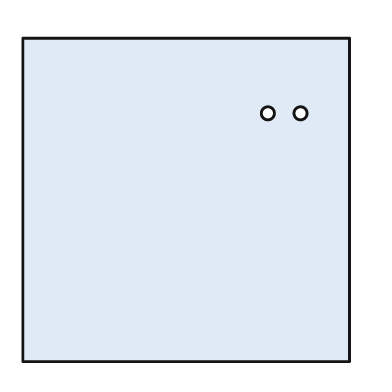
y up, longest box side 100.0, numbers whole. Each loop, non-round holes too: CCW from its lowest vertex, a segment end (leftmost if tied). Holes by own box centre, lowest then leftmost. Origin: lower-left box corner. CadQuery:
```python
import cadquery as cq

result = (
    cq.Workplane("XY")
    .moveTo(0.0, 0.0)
    .lineTo(100.0, 0.0)
    .lineTo(100.0, 99.0)
    .lineTo(0.0, 99.0)
    .close()
    .moveTo(75.0, 76.0)
    .circle(2.0)
    .moveTo(85.0, 76.0)
    .circle(2.0)
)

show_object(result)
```